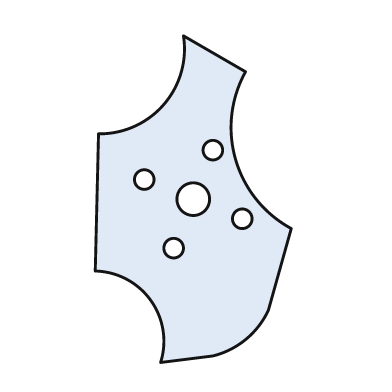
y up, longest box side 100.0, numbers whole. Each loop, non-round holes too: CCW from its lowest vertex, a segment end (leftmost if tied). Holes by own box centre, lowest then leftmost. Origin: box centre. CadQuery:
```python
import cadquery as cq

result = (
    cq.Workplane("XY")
    .moveTo(-10.0, -50.0)
    .lineTo(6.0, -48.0)
    .threePointArc((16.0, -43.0), (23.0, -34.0))
    .lineTo(30.0, -9.0)
    .threePointArc((13.0, 12.0), (16.0, 39.0))
    .lineTo(-3.0, 50.0)
    .threePointArc((-9.0, 29.0), (-29.0, 20.0))
    .lineTo(-30.0, -22.0)
    .threePointArc((-13.0, -31.0), (-10.0, -50.0))
    .close()
    .moveTo(-6.0, -15.0)
    .circle(3.0)
    .moveTo(15.0, -6.0)
    .circle(3.0)
    .moveTo(0.0, 0.0)
    .circle(5.0)
    .moveTo(-15.0, 6.0)
    .circle(3.0)
    .moveTo(6.0, 15.0)
    .circle(3.0)
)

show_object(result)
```